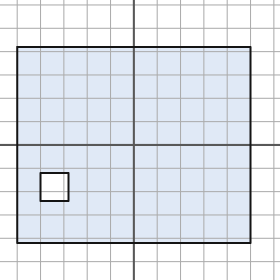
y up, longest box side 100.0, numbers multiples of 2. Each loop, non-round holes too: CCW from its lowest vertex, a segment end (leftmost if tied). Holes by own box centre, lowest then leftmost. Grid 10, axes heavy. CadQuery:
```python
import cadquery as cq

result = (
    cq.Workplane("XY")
    .moveTo(-50.0, -42.0)
    .lineTo(50.0, -42.0)
    .lineTo(50.0, 42.0)
    .lineTo(-50.0, 42.0)
    .close()
    .moveTo(-40.0, -24.0)
    .lineTo(-28.0, -24.0)
    .lineTo(-28.0, -12.0)
    .lineTo(-40.0, -12.0)
    .close()
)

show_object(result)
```